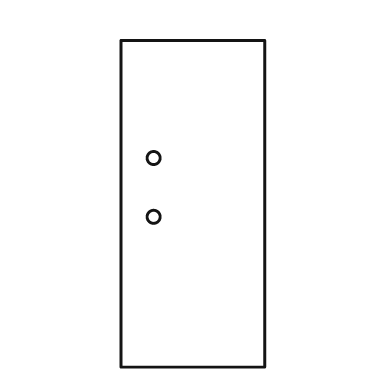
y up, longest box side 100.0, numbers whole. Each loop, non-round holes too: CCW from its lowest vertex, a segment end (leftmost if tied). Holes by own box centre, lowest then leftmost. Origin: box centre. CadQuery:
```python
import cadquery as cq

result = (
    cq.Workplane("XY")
    .moveTo(-22.0, -50.0)
    .lineTo(22.0, -50.0)
    .lineTo(22.0, 50.0)
    .lineTo(-22.0, 50.0)
    .close()
    .moveTo(-12.0, -4.0)
    .circle(2.0)
    .moveTo(-12.0, 14.0)
    .circle(2.0)
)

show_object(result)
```